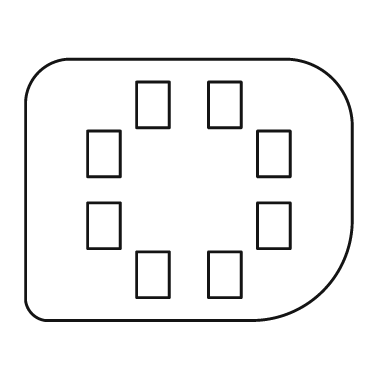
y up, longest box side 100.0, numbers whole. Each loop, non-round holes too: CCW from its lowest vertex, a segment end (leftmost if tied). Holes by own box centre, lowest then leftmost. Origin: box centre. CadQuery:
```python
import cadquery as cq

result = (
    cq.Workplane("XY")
    .moveTo(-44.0, -40.0)
    .lineTo(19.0, -40.0)
    .threePointArc((41.0, -31.0), (50.0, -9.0))
    .lineTo(50.0, 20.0)
    .threePointArc((44.0, 34.0), (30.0, 40.0))
    .lineTo(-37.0, 40.0)
    .threePointArc((-46.0, 36.0), (-50.0, 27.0))
    .lineTo(-50.0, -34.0)
    .threePointArc((-48.0, -38.0), (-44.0, -40.0))
    .close()
    .moveTo(-16.0, -33.0)
    .lineTo(-6.0, -33.0)
    .lineTo(-6.0, -19.0)
    .lineTo(-16.0, -19.0)
    .close()
    .moveTo(6.0, -33.0)
    .lineTo(16.0, -33.0)
    .lineTo(16.0, -19.0)
    .lineTo(6.0, -19.0)
    .close()
    .moveTo(-31.0, -18.0)
    .lineTo(-21.0, -18.0)
    .lineTo(-21.0, -4.0)
    .lineTo(-31.0, -4.0)
    .close()
    .moveTo(21.0, -18.0)
    .lineTo(31.0, -18.0)
    .lineTo(31.0, -4.0)
    .lineTo(21.0, -4.0)
    .close()
    .moveTo(-31.0, 4.0)
    .lineTo(-21.0, 4.0)
    .lineTo(-21.0, 18.0)
    .lineTo(-31.0, 18.0)
    .close()
    .moveTo(21.0, 4.0)
    .lineTo(31.0, 4.0)
    .lineTo(31.0, 18.0)
    .lineTo(21.0, 18.0)
    .close()
    .moveTo(-16.0, 19.0)
    .lineTo(-6.0, 19.0)
    .lineTo(-6.0, 33.0)
    .lineTo(-16.0, 33.0)
    .close()
    .moveTo(6.0, 19.0)
    .lineTo(16.0, 19.0)
    .lineTo(16.0, 33.0)
    .lineTo(6.0, 33.0)
    .close()
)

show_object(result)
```